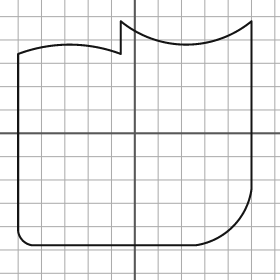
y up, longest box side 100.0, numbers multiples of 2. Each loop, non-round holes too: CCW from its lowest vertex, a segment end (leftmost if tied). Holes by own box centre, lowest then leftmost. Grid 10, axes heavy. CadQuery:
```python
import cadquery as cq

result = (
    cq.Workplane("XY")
    .moveTo(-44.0, -48.0)
    .lineTo(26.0, -48.0)
    .threePointArc((42.0, -40.0), (50.0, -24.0))
    .lineTo(50.0, 48.0)
    .threePointArc((22.0, 38.0), (-6.0, 48.0))
    .lineTo(-6.0, 34.0)
    .threePointArc((-28.0, 38.0), (-50.0, 34.0))
    .lineTo(-50.0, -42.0)
    .threePointArc((-48.0, -46.0), (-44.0, -48.0))
    .close()
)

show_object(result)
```